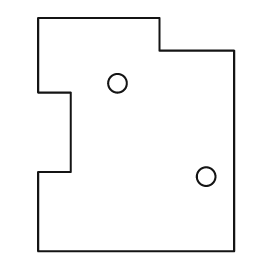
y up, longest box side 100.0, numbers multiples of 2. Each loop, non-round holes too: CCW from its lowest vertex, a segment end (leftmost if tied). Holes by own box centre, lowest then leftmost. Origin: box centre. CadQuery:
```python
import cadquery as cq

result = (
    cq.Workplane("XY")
    .moveTo(-42.0, -50.0)
    .lineTo(42.0, -50.0)
    .lineTo(42.0, 36.0)
    .lineTo(10.0, 36.0)
    .lineTo(10.0, 50.0)
    .lineTo(-42.0, 50.0)
    .lineTo(-42.0, 18.0)
    .lineTo(-28.0, 18.0)
    .lineTo(-28.0, -16.0)
    .lineTo(-42.0, -16.0)
    .close()
    .moveTo(30.0, -18.0)
    .circle(4.0)
    .moveTo(-8.0, 22.0)
    .circle(4.0)
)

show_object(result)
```